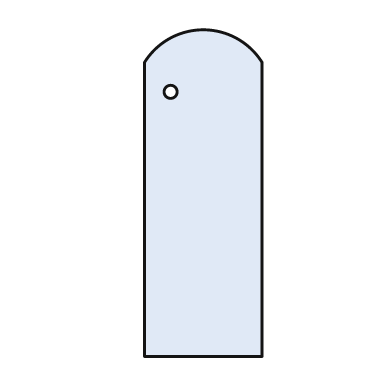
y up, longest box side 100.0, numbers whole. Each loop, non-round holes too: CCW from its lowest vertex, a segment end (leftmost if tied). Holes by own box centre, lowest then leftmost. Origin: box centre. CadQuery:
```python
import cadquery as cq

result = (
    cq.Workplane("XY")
    .moveTo(-18.0, -50.0)
    .lineTo(18.0, -50.0)
    .lineTo(18.0, 40.0)
    .threePointArc((0.0, 50.0), (-18.0, 40.0))
    .close()
    .moveTo(-10.0, 31.0)
    .circle(2.0)
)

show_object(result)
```